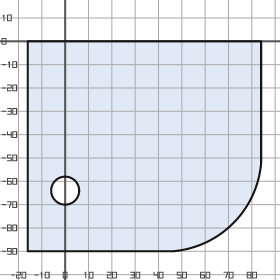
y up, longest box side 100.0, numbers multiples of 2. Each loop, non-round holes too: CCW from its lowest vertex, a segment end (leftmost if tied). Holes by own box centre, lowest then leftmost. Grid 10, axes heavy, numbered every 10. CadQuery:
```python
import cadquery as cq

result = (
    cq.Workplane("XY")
    .moveTo(-16.0, -90.0)
    .lineTo(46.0, -90.0)
    .threePointArc((72.0, -78.0), (84.0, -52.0))
    .lineTo(84.0, 0.0)
    .lineTo(-16.0, 0.0)
    .close()
    .moveTo(0.0, -64.0)
    .circle(6.0)
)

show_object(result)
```